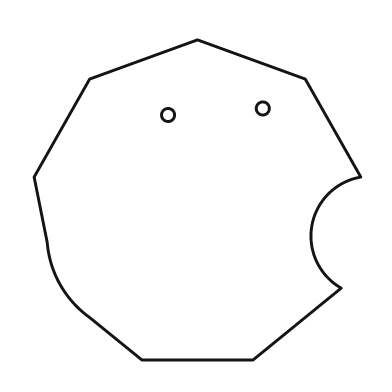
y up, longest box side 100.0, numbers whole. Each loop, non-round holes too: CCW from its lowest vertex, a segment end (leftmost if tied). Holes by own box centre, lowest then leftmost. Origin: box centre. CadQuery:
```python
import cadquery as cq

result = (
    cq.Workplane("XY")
    .moveTo(-17.0, -49.0)
    .lineTo(17.0, -49.0)
    .lineTo(44.0, -27.0)
    .threePointArc((35.0, -8.0), (50.0, 7.0))
    .lineTo(33.0, 37.0)
    .lineTo(0.0, 49.0)
    .lineTo(-33.0, 37.0)
    .lineTo(-50.0, 7.0)
    .lineTo(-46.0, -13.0)
    .threePointArc((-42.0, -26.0), (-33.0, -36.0))
    .close()
    .moveTo(-9.0, 26.0)
    .circle(2.0)
    .moveTo(20.0, 28.0)
    .circle(2.0)
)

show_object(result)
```